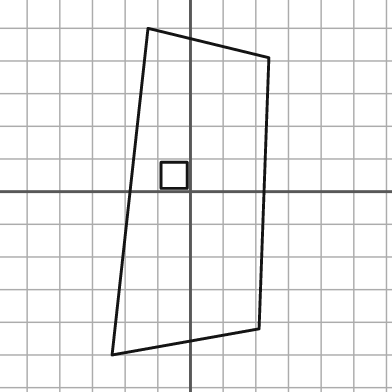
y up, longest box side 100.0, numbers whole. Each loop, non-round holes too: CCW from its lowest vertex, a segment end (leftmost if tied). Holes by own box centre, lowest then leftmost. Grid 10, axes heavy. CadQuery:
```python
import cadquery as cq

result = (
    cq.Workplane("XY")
    .moveTo(-24.0, -50.0)
    .lineTo(21.0, -42.0)
    .lineTo(24.0, 41.0)
    .lineTo(-13.0, 50.0)
    .close()
    .moveTo(-9.0, 1.0)
    .lineTo(-1.0, 1.0)
    .lineTo(-1.0, 9.0)
    .lineTo(-9.0, 9.0)
    .close()
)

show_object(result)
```